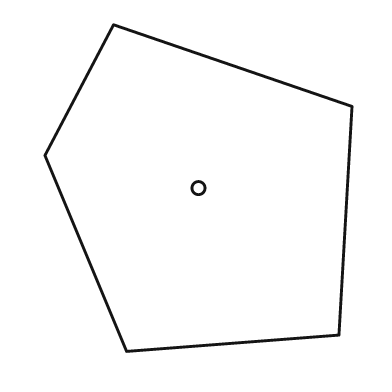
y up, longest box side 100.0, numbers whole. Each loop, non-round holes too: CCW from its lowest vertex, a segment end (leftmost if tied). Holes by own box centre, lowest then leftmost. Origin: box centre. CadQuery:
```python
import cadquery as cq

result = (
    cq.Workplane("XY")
    .moveTo(-22.0, -50.0)
    .lineTo(43.0, -45.0)
    .lineTo(47.0, 25.0)
    .lineTo(-26.0, 50.0)
    .lineTo(-47.0, 10.0)
    .close()
    .moveTo(0.0, 0.0)
    .circle(2.0)
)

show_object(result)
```